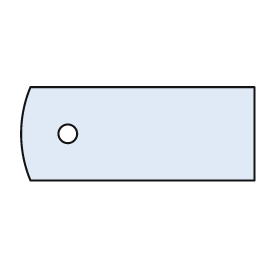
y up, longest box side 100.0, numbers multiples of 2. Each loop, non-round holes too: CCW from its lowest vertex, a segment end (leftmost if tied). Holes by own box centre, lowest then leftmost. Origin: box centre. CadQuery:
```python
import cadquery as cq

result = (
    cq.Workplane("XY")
    .moveTo(-46.0, -20.0)
    .lineTo(50.0, -20.0)
    .lineTo(50.0, 20.0)
    .lineTo(-46.0, 20.0)
    .threePointArc((-50.0, 0.0), (-46.0, -20.0))
    .close()
    .moveTo(-30.0, 0.0)
    .circle(4.0)
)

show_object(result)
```